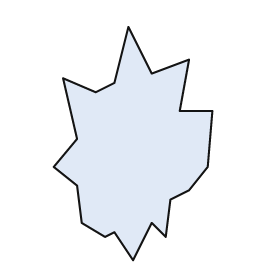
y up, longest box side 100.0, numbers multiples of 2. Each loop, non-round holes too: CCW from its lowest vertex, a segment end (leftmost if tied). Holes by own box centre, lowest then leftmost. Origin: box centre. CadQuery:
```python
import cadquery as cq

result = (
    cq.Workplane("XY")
    .moveTo(0.0, -50.0)
    .lineTo(8.0, -34.0)
    .lineTo(14.0, -40.0)
    .lineTo(16.0, -24.0)
    .lineTo(24.0, -20.0)
    .lineTo(32.0, -10.0)
    .lineTo(34.0, 14.0)
    .lineTo(20.0, 14.0)
    .lineTo(24.0, 36.0)
    .lineTo(8.0, 30.0)
    .lineTo(-2.0, 50.0)
    .lineTo(-8.0, 26.0)
    .lineTo(-16.0, 22.0)
    .lineTo(-30.0, 28.0)
    .lineTo(-24.0, 2.0)
    .lineTo(-34.0, -10.0)
    .lineTo(-24.0, -18.0)
    .lineTo(-22.0, -34.0)
    .lineTo(-12.0, -40.0)
    .lineTo(-8.0, -38.0)
    .close()
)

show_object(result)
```